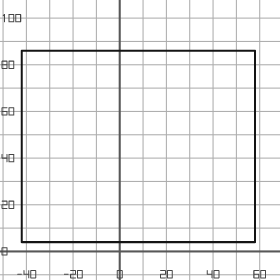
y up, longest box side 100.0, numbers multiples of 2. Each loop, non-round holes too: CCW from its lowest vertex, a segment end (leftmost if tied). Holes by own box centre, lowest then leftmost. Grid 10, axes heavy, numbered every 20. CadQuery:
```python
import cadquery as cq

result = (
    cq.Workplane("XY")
    .moveTo(-42.0, 4.0)
    .lineTo(58.0, 4.0)
    .lineTo(58.0, 86.0)
    .lineTo(-42.0, 86.0)
    .close()
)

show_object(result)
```